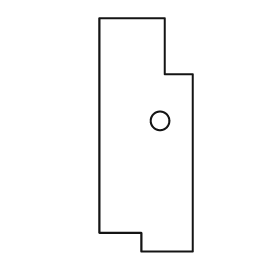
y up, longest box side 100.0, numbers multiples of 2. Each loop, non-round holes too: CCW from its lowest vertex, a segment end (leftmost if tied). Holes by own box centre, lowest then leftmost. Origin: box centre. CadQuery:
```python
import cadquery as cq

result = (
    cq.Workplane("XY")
    .moveTo(-2.0, -50.0)
    .lineTo(20.0, -50.0)
    .lineTo(20.0, 26.0)
    .lineTo(8.0, 26.0)
    .lineTo(8.0, 50.0)
    .lineTo(-20.0, 50.0)
    .lineTo(-20.0, -42.0)
    .lineTo(-2.0, -42.0)
    .close()
    .moveTo(6.0, 6.0)
    .circle(4.0)
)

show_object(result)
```